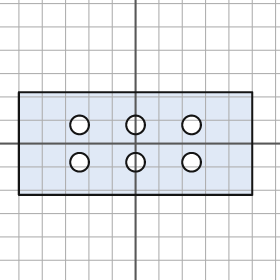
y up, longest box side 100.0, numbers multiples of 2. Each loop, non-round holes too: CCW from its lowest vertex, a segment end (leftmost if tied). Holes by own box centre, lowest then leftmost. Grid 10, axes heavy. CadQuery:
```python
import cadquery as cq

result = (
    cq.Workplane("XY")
    .moveTo(-50.0, -22.0)
    .lineTo(50.0, -22.0)
    .lineTo(50.0, 22.0)
    .lineTo(-50.0, 22.0)
    .close()
    .moveTo(-24.0, -8.0)
    .circle(4.0)
    .moveTo(0.0, -8.0)
    .circle(4.0)
    .moveTo(24.0, -8.0)
    .circle(4.0)
    .moveTo(-24.0, 8.0)
    .circle(4.0)
    .moveTo(0.0, 8.0)
    .circle(4.0)
    .moveTo(24.0, 8.0)
    .circle(4.0)
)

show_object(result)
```